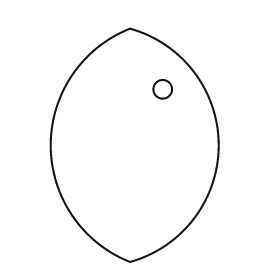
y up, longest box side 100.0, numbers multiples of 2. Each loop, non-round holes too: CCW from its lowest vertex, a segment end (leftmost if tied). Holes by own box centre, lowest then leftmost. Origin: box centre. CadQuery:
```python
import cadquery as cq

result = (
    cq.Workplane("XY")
    .moveTo(-2.0, -50.0)
    .threePointArc((36.0, 0.0), (-2.0, 50.0))
    .threePointArc((-36.0, 0.0), (-2.0, -50.0))
    .close()
    .moveTo(12.0, 24.0)
    .circle(4.0)
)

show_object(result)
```